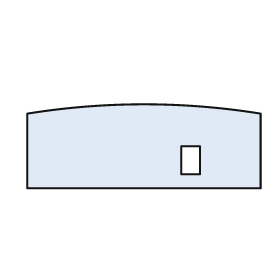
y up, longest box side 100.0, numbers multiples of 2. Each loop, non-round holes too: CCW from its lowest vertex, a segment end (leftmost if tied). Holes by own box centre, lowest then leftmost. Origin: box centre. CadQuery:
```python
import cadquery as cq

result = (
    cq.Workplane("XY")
    .moveTo(-50.0, -18.0)
    .lineTo(50.0, -18.0)
    .lineTo(50.0, 14.0)
    .threePointArc((0.0, 18.0), (-50.0, 14.0))
    .close()
    .moveTo(16.0, -12.0)
    .lineTo(24.0, -12.0)
    .lineTo(24.0, 0.0)
    .lineTo(16.0, 0.0)
    .close()
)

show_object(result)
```